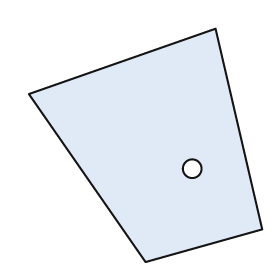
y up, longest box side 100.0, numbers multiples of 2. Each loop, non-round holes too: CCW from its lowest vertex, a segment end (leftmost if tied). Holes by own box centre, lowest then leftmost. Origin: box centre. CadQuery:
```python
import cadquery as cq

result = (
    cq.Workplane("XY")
    .moveTo(0.0, -50.0)
    .lineTo(50.0, -36.0)
    .lineTo(30.0, 50.0)
    .lineTo(-50.0, 22.0)
    .close()
    .moveTo(20.0, -10.0)
    .circle(4.0)
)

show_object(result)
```